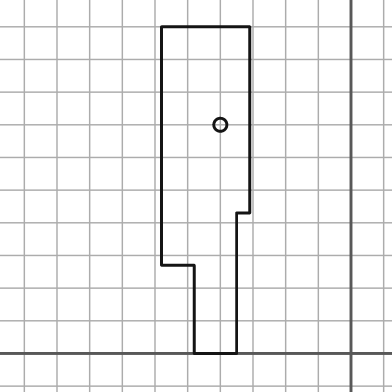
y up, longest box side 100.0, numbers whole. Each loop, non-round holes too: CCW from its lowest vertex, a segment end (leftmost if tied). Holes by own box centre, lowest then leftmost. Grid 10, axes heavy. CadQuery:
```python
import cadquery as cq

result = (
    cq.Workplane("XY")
    .moveTo(-48.0, 0.0)
    .lineTo(-35.0, 0.0)
    .lineTo(-35.0, 43.0)
    .lineTo(-31.0, 43.0)
    .lineTo(-31.0, 100.0)
    .lineTo(-58.0, 100.0)
    .lineTo(-58.0, 27.0)
    .lineTo(-48.0, 27.0)
    .close()
    .moveTo(-40.0, 70.0)
    .circle(2.0)
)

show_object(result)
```